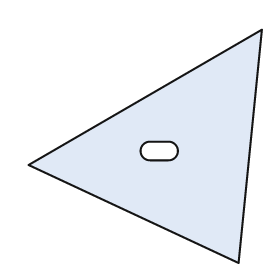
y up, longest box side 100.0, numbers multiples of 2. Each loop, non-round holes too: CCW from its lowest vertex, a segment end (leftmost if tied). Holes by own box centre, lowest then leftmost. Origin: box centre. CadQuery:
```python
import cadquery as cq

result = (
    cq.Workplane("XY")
    .moveTo(40.0, -50.0)
    .lineTo(50.0, 50.0)
    .lineTo(-50.0, -8.0)
    .close()
    .moveTo(2.0, -6.0)
    .lineTo(10.0, -6.0)
    .threePointArc((14.0, -2.0), (10.0, 2.0))
    .lineTo(2.0, 2.0)
    .threePointArc((-2.0, -2.0), (2.0, -6.0))
    .close()
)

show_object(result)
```